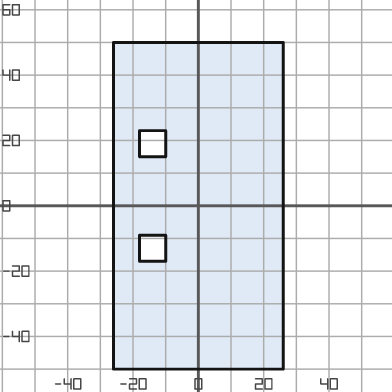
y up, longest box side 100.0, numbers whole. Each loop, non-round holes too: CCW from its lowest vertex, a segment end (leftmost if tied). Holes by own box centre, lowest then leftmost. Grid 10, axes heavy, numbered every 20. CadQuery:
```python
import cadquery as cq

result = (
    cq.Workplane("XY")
    .moveTo(-26.0, -50.0)
    .lineTo(26.0, -50.0)
    .lineTo(26.0, 50.0)
    .lineTo(-26.0, 50.0)
    .close()
    .moveTo(-18.0, -17.0)
    .lineTo(-10.0, -17.0)
    .lineTo(-10.0, -9.0)
    .lineTo(-18.0, -9.0)
    .close()
    .moveTo(-18.0, 15.0)
    .lineTo(-10.0, 15.0)
    .lineTo(-10.0, 23.0)
    .lineTo(-18.0, 23.0)
    .close()
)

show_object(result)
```